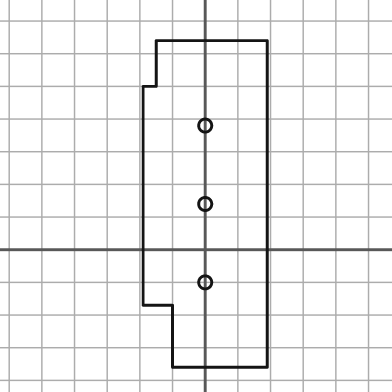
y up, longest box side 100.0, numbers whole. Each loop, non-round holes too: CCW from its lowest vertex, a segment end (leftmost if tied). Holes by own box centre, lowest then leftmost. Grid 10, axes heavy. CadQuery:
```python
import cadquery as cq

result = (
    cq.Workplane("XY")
    .moveTo(-10.0, -36.0)
    .lineTo(19.0, -36.0)
    .lineTo(19.0, 64.0)
    .lineTo(-15.0, 64.0)
    .lineTo(-15.0, 50.0)
    .lineTo(-19.0, 50.0)
    .lineTo(-19.0, -17.0)
    .lineTo(-10.0, -17.0)
    .close()
    .moveTo(0.0, -10.0)
    .circle(2.0)
    .moveTo(0.0, 14.0)
    .circle(2.0)
    .moveTo(0.0, 38.0)
    .circle(2.0)
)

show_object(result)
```